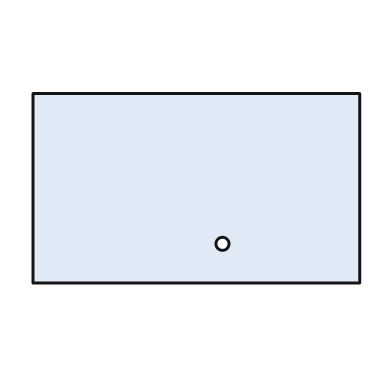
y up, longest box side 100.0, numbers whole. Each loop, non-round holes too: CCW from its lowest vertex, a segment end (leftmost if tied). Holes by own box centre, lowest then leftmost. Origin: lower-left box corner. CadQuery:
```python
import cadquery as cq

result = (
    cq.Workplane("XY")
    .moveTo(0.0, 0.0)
    .lineTo(100.0, 0.0)
    .lineTo(100.0, 58.0)
    .lineTo(0.0, 58.0)
    .close()
    .moveTo(58.0, 12.0)
    .circle(2.0)
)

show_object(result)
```